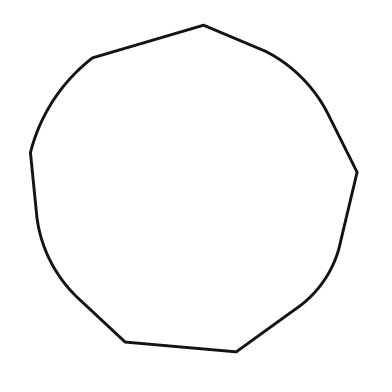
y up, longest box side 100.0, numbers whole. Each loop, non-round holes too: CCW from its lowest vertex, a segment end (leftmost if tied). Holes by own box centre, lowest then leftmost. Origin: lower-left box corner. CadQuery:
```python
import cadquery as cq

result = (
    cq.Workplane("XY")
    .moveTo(63.0, 0.0)
    .lineTo(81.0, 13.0)
    .threePointArc((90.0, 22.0), (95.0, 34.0))
    .lineTo(100.0, 55.0)
    .lineTo(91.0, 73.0)
    .threePointArc((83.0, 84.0), (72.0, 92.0))
    .lineTo(53.0, 100.0)
    .lineTo(19.0, 90.0)
    .threePointArc((7.0, 77.0), (0.0, 61.0))
    .lineTo(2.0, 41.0)
    .threePointArc((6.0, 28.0), (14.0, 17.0))
    .lineTo(29.0, 3.0)
    .close()
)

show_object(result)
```